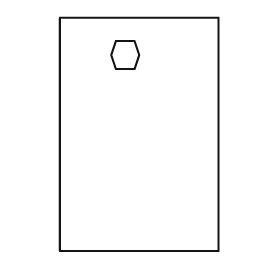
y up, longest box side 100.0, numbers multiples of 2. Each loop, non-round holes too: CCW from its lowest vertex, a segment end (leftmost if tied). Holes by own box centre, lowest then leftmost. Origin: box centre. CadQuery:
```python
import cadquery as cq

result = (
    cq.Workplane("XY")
    .moveTo(-34.0, -50.0)
    .lineTo(34.0, -50.0)
    .lineTo(34.0, 50.0)
    .lineTo(-34.0, 50.0)
    .close()
    .moveTo(-10.0, 28.0)
    .lineTo(-2.0, 28.0)
    .lineTo(0.0, 34.0)
    .lineTo(-2.0, 40.0)
    .lineTo(-10.0, 40.0)
    .lineTo(-12.0, 34.0)
    .close()
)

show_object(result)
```